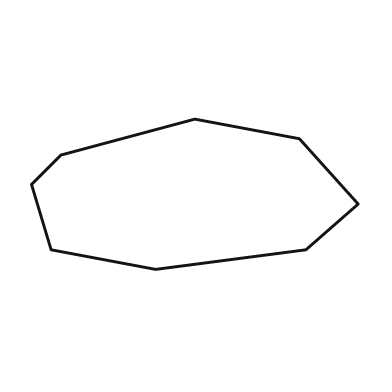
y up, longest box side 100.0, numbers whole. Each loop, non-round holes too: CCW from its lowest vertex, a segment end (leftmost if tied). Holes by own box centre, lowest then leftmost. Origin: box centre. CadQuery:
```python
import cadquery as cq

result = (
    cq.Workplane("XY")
    .moveTo(-12.0, -23.0)
    .lineTo(34.0, -17.0)
    .lineTo(50.0, -3.0)
    .lineTo(32.0, 17.0)
    .lineTo(0.0, 23.0)
    .lineTo(-41.0, 12.0)
    .lineTo(-50.0, 3.0)
    .lineTo(-44.0, -17.0)
    .close()
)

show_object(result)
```